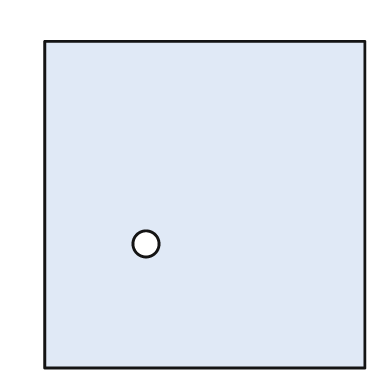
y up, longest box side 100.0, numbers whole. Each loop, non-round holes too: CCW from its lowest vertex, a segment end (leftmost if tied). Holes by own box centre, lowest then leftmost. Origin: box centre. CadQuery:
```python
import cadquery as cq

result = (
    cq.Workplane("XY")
    .moveTo(-49.0, -50.0)
    .lineTo(49.0, -50.0)
    .lineTo(49.0, 50.0)
    .lineTo(-49.0, 50.0)
    .close()
    .moveTo(-18.0, -12.0)
    .circle(4.0)
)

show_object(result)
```